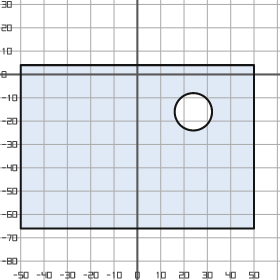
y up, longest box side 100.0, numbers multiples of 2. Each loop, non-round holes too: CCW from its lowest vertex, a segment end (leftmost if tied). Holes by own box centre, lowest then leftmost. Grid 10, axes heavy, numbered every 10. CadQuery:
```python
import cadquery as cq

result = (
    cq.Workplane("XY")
    .moveTo(-50.0, -66.0)
    .lineTo(50.0, -66.0)
    .lineTo(50.0, 4.0)
    .lineTo(-50.0, 4.0)
    .close()
    .moveTo(24.0, -16.0)
    .circle(8.0)
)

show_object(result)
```